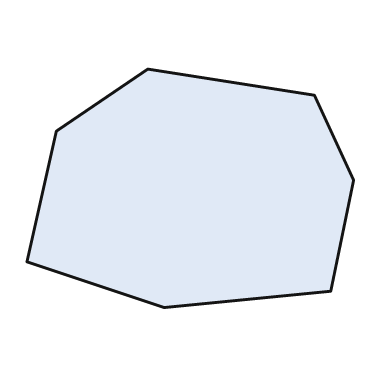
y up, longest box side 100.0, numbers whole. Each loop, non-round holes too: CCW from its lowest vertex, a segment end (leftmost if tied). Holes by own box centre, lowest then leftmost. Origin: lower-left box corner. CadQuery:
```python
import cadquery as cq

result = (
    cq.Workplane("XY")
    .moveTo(42.0, 0.0)
    .lineTo(93.0, 5.0)
    .lineTo(100.0, 39.0)
    .lineTo(88.0, 65.0)
    .lineTo(37.0, 73.0)
    .lineTo(9.0, 54.0)
    .lineTo(0.0, 14.0)
    .close()
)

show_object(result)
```